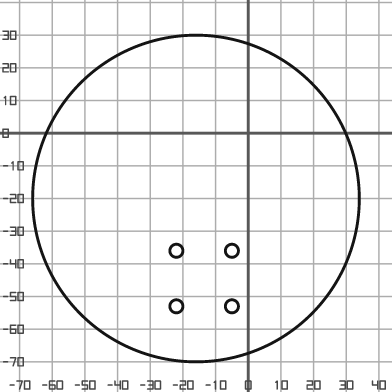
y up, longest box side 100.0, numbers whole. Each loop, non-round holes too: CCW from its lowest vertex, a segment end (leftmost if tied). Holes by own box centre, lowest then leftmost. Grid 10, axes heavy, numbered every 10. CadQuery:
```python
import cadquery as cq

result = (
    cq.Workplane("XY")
    .moveTo(-16.0, -20.0)
    .circle(50.0)
    .moveTo(-22.0, -53.0)
    .circle(2.0)
    .moveTo(-5.0, -53.0)
    .circle(2.0)
    .moveTo(-22.0, -36.0)
    .circle(2.0)
    .moveTo(-5.0, -36.0)
    .circle(2.0)
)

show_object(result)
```